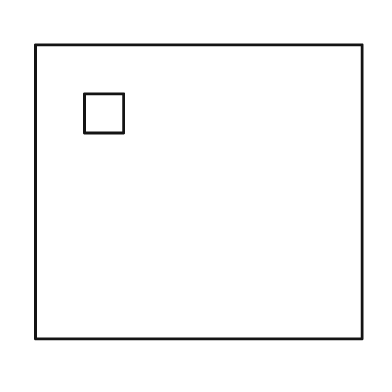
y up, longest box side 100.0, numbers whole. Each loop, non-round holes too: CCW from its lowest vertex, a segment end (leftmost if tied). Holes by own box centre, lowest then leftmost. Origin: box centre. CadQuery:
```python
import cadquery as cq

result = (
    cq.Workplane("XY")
    .moveTo(-50.0, -45.0)
    .lineTo(50.0, -45.0)
    .lineTo(50.0, 45.0)
    .lineTo(-50.0, 45.0)
    .close()
    .moveTo(-35.0, 18.0)
    .lineTo(-23.0, 18.0)
    .lineTo(-23.0, 30.0)
    .lineTo(-35.0, 30.0)
    .close()
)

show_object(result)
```